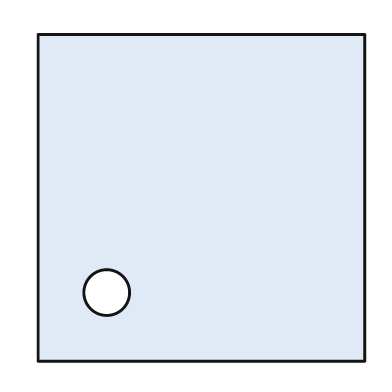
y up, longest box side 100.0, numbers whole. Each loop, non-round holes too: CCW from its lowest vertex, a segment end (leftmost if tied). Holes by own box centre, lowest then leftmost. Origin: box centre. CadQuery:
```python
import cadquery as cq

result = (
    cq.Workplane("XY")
    .moveTo(-50.0, -50.0)
    .lineTo(50.0, -50.0)
    .lineTo(50.0, 50.0)
    .lineTo(-50.0, 50.0)
    .close()
    .moveTo(-29.0, -29.0)
    .circle(7.0)
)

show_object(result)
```